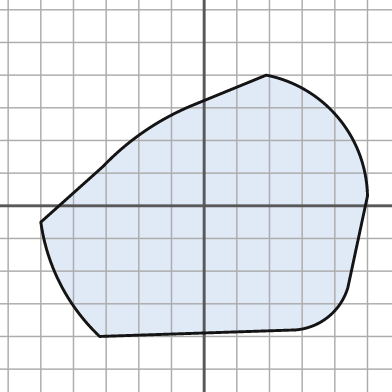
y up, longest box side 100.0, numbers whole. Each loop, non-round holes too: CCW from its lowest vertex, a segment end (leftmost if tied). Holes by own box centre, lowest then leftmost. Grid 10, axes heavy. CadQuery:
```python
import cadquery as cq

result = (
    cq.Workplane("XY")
    .moveTo(-32.0, -40.0)
    .lineTo(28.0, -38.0)
    .threePointArc((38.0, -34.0), (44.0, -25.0))
    .lineTo(50.0, 3.0)
    .threePointArc((41.0, 27.0), (19.0, 40.0))
    .lineTo(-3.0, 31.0)
    .threePointArc((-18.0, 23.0), (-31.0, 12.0))
    .lineTo(-50.0, -5.0)
    .threePointArc((-44.0, -24.0), (-32.0, -40.0))
    .close()
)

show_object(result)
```